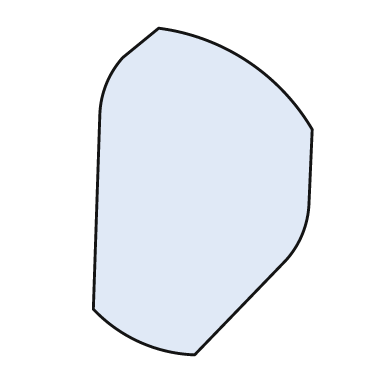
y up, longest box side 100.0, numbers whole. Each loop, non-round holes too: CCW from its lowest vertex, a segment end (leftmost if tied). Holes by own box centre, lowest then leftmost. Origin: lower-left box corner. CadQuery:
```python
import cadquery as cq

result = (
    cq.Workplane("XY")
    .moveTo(31.0, 0.0)
    .lineTo(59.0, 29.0)
    .threePointArc((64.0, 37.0), (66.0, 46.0))
    .lineTo(67.0, 69.0)
    .threePointArc((47.0, 90.0), (20.0, 100.0))
    .lineTo(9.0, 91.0)
    .threePointArc((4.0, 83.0), (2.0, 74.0))
    .lineTo(0.0, 14.0)
    .threePointArc((14.0, 4.0), (31.0, 0.0))
    .close()
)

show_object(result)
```